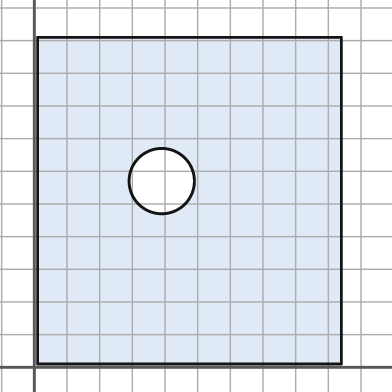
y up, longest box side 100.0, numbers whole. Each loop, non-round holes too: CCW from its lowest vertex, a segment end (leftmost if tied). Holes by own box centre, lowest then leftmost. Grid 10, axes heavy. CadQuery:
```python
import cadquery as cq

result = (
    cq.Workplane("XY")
    .moveTo(1.0, 1.0)
    .lineTo(94.0, 1.0)
    .lineTo(94.0, 101.0)
    .lineTo(1.0, 101.0)
    .close()
    .moveTo(39.0, 57.0)
    .circle(10.0)
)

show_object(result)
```